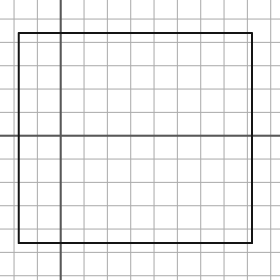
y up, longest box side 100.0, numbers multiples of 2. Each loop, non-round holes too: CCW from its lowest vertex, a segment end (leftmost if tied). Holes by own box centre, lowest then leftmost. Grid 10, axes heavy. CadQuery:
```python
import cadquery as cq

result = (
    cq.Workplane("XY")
    .moveTo(-18.0, -46.0)
    .lineTo(82.0, -46.0)
    .lineTo(82.0, 44.0)
    .lineTo(-18.0, 44.0)
    .close()
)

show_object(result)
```